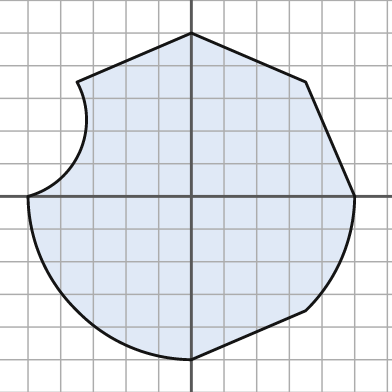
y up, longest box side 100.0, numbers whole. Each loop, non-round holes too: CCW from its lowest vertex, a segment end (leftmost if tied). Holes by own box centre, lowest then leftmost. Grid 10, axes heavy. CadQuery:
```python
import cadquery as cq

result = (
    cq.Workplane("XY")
    .moveTo(0.0, -50.0)
    .lineTo(35.0, -35.0)
    .threePointArc((46.0, -19.0), (50.0, 0.0))
    .lineTo(35.0, 35.0)
    .lineTo(0.0, 50.0)
    .lineTo(-35.0, 35.0)
    .threePointArc((-34.0, 14.0), (-50.0, 0.0))
    .threePointArc((-46.0, -19.0), (-35.0, -35.0))
    .threePointArc((-19.0, -46.0), (0.0, -50.0))
    .close()
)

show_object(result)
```